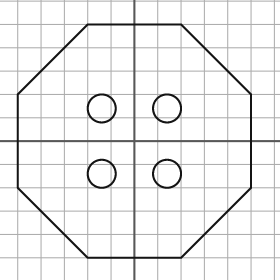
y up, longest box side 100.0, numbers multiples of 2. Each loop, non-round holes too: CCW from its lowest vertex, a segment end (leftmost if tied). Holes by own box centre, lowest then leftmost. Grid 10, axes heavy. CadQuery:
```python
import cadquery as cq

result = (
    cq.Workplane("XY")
    .moveTo(-20.0, -50.0)
    .lineTo(20.0, -50.0)
    .lineTo(50.0, -20.0)
    .lineTo(50.0, 20.0)
    .lineTo(20.0, 50.0)
    .lineTo(-20.0, 50.0)
    .lineTo(-50.0, 20.0)
    .lineTo(-50.0, -20.0)
    .close()
    .moveTo(-14.0, -14.0)
    .circle(6.0)
    .moveTo(14.0, -14.0)
    .circle(6.0)
    .moveTo(-14.0, 14.0)
    .circle(6.0)
    .moveTo(14.0, 14.0)
    .circle(6.0)
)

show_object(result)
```